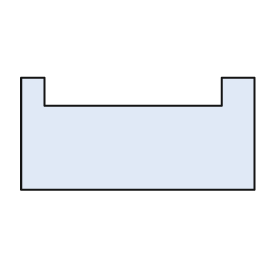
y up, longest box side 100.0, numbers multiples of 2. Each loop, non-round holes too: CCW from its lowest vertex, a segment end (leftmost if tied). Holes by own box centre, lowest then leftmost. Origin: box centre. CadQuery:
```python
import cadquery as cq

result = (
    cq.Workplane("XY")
    .moveTo(-50.0, -24.0)
    .lineTo(50.0, -24.0)
    .lineTo(50.0, 24.0)
    .lineTo(36.0, 24.0)
    .lineTo(36.0, 12.0)
    .lineTo(-40.0, 12.0)
    .lineTo(-40.0, 24.0)
    .lineTo(-50.0, 24.0)
    .close()
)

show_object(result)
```